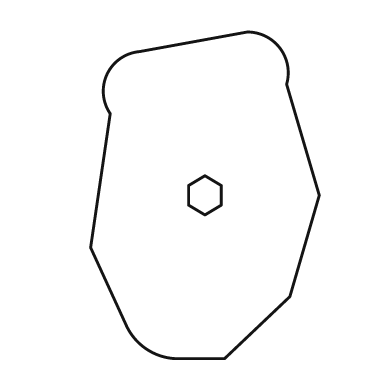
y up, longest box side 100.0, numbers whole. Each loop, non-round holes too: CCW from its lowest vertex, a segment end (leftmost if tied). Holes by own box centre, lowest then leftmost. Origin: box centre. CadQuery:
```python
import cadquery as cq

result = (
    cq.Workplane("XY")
    .moveTo(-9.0, -50.0)
    .lineTo(6.0, -50.0)
    .lineTo(26.0, -31.0)
    .lineTo(35.0, 0.0)
    .lineTo(25.0, 34.0)
    .threePointArc((23.0, 45.0), (13.0, 50.0))
    .lineTo(-20.0, 44.0)
    .threePointArc((-30.0, 37.0), (-29.0, 25.0))
    .lineTo(-35.0, -16.0)
    .lineTo(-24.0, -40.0)
    .threePointArc((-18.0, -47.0), (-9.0, -50.0))
    .close()
    .moveTo(0.0, -6.0)
    .lineTo(5.0, -3.0)
    .lineTo(5.0, 3.0)
    .lineTo(0.0, 6.0)
    .lineTo(-5.0, 3.0)
    .lineTo(-5.0, -3.0)
    .close()
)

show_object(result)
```